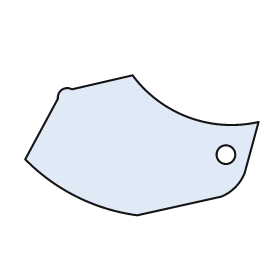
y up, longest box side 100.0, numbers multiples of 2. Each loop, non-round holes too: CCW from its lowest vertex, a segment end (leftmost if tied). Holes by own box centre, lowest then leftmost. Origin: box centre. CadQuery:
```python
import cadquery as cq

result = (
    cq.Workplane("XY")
    .moveTo(-2.0, -30.0)
    .lineTo(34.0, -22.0)
    .threePointArc((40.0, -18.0), (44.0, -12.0))
    .lineTo(50.0, 10.0)
    .threePointArc((20.0, 12.0), (-4.0, 30.0))
    .lineTo(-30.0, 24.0)
    .threePointArc((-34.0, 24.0), (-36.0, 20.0))
    .lineTo(-50.0, -6.0)
    .threePointArc((-28.0, -22.0), (-2.0, -30.0))
    .close()
    .moveTo(36.0, -4.0)
    .circle(4.0)
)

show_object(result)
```